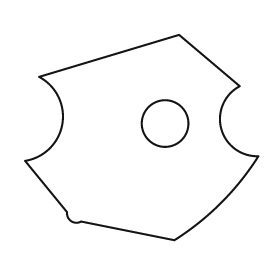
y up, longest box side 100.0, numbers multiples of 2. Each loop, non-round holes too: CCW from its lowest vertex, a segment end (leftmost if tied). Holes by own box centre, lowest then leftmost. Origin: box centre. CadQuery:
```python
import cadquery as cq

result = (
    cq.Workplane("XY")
    .moveTo(14.0, -44.0)
    .threePointArc((34.0, -28.0), (50.0, -8.0))
    .threePointArc((34.0, 4.0), (42.0, 22.0))
    .lineTo(16.0, 44.0)
    .lineTo(-44.0, 26.0)
    .threePointArc((-34.0, 6.0), (-50.0, -10.0))
    .lineTo(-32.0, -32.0)
    .threePointArc((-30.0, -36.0), (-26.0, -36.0))
    .close()
    .moveTo(10.0, 6.0)
    .circle(10.0)
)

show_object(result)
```